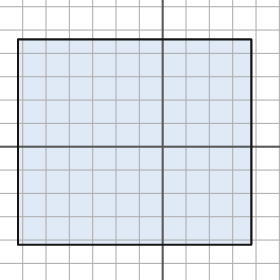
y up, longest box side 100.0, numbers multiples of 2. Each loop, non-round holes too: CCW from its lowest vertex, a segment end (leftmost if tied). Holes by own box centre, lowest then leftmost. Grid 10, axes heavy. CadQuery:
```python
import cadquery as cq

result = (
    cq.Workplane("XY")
    .moveTo(-62.0, -42.0)
    .lineTo(38.0, -42.0)
    .lineTo(38.0, 46.0)
    .lineTo(-62.0, 46.0)
    .close()
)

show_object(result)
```